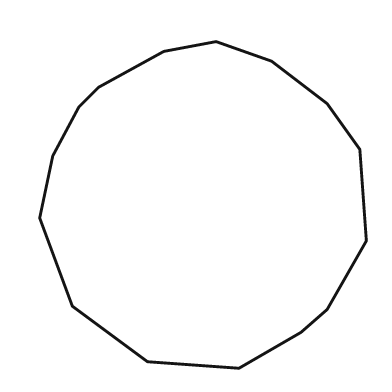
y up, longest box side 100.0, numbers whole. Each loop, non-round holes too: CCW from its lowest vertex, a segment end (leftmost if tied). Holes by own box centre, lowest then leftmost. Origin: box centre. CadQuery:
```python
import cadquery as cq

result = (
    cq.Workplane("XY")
    .moveTo(11.0, -50.0)
    .lineTo(30.0, -39.0)
    .lineTo(38.0, -32.0)
    .lineTo(50.0, -11.0)
    .lineTo(48.0, 17.0)
    .lineTo(38.0, 31.0)
    .lineTo(21.0, 44.0)
    .lineTo(4.0, 50.0)
    .lineTo(-12.0, 47.0)
    .lineTo(-32.0, 36.0)
    .lineTo(-38.0, 30.0)
    .lineTo(-46.0, 15.0)
    .lineTo(-50.0, -4.0)
    .lineTo(-40.0, -31.0)
    .lineTo(-17.0, -48.0)
    .close()
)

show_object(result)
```